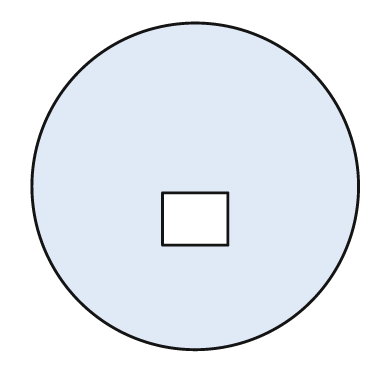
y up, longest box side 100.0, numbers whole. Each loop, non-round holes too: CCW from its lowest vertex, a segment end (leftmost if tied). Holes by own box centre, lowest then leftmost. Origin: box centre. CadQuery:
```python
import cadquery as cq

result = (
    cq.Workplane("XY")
    .moveTo(0.0, 0.0)
    .circle(50.0)
    .moveTo(-10.0, -18.0)
    .lineTo(10.0, -18.0)
    .lineTo(10.0, -2.0)
    .lineTo(-10.0, -2.0)
    .close()
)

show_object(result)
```